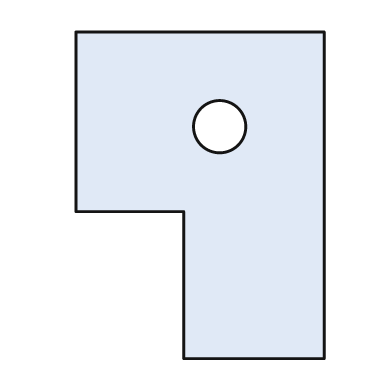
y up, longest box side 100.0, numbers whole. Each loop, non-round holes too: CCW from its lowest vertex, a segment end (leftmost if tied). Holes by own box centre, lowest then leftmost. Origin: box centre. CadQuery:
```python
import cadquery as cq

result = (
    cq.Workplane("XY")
    .moveTo(-5.0, -50.0)
    .lineTo(38.0, -50.0)
    .lineTo(38.0, 50.0)
    .lineTo(-38.0, 50.0)
    .lineTo(-38.0, -5.0)
    .lineTo(-5.0, -5.0)
    .close()
    .moveTo(6.0, 21.0)
    .circle(8.0)
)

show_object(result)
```